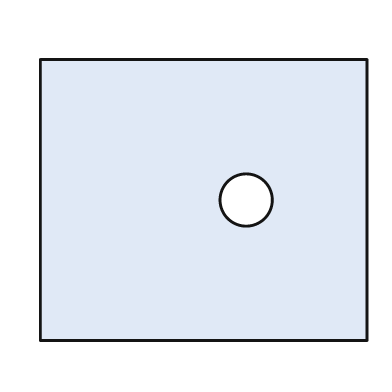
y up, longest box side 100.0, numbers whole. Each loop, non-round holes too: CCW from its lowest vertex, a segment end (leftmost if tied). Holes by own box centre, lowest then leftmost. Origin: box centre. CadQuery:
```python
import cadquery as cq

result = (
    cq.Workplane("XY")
    .moveTo(-50.0, -43.0)
    .lineTo(50.0, -43.0)
    .lineTo(50.0, 43.0)
    .lineTo(-50.0, 43.0)
    .close()
    .moveTo(13.0, 0.0)
    .circle(8.0)
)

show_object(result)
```